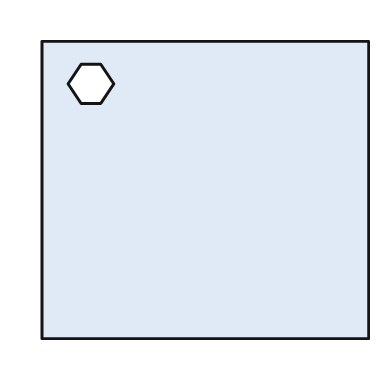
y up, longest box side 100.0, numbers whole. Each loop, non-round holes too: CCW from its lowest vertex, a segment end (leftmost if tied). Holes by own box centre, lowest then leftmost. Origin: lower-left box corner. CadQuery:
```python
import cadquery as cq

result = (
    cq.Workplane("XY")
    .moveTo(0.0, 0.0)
    .lineTo(100.0, 0.0)
    .lineTo(100.0, 91.0)
    .lineTo(0.0, 91.0)
    .close()
    .moveTo(12.0, 72.0)
    .lineTo(18.0, 72.0)
    .lineTo(22.0, 78.0)
    .lineTo(18.0, 84.0)
    .lineTo(12.0, 84.0)
    .lineTo(8.0, 78.0)
    .close()
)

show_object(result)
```